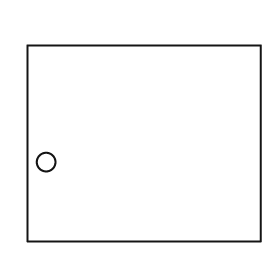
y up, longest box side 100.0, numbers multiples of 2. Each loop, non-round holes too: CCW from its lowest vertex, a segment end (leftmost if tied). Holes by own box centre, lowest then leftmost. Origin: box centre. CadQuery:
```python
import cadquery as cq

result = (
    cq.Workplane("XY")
    .moveTo(-50.0, -42.0)
    .lineTo(50.0, -42.0)
    .lineTo(50.0, 42.0)
    .lineTo(-50.0, 42.0)
    .close()
    .moveTo(-42.0, -8.0)
    .circle(4.0)
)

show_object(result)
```